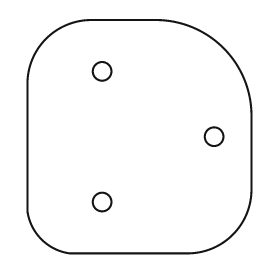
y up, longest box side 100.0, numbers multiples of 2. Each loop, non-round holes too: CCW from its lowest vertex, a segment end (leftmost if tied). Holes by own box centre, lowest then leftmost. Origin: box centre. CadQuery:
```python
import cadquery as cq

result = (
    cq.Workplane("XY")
    .moveTo(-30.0, -50.0)
    .lineTo(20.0, -50.0)
    .threePointArc((40.0, -42.0), (48.0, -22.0))
    .lineTo(48.0, 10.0)
    .threePointArc((36.0, 38.0), (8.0, 50.0))
    .lineTo(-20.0, 50.0)
    .threePointArc((-40.0, 42.0), (-48.0, 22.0))
    .lineTo(-48.0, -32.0)
    .threePointArc((-42.0, -44.0), (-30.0, -50.0))
    .close()
    .moveTo(-16.0, -28.0)
    .circle(4.0)
    .moveTo(32.0, 0.0)
    .circle(4.0)
    .moveTo(-16.0, 28.0)
    .circle(4.0)
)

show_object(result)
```